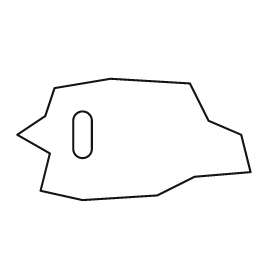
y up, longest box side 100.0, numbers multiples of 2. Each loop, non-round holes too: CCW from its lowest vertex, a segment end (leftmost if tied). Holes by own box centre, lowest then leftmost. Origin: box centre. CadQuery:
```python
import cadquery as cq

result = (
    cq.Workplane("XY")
    .moveTo(-22.0, -26.0)
    .lineTo(10.0, -24.0)
    .lineTo(26.0, -16.0)
    .lineTo(50.0, -14.0)
    .lineTo(46.0, 2.0)
    .lineTo(32.0, 8.0)
    .lineTo(24.0, 24.0)
    .lineTo(-10.0, 26.0)
    .lineTo(-34.0, 22.0)
    .lineTo(-38.0, 10.0)
    .lineTo(-50.0, 2.0)
    .lineTo(-36.0, -6.0)
    .lineTo(-40.0, -22.0)
    .close()
    .moveTo(-26.0, -4.0)
    .threePointArc((-22.0, -8.0), (-18.0, -4.0))
    .lineTo(-18.0, 8.0)
    .threePointArc((-22.0, 12.0), (-26.0, 8.0))
    .close()
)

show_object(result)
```